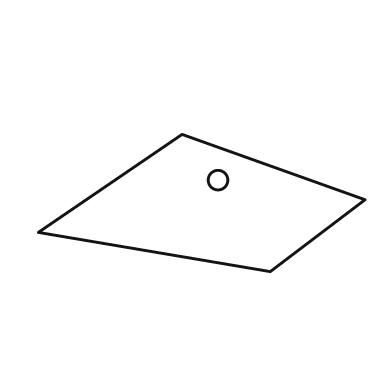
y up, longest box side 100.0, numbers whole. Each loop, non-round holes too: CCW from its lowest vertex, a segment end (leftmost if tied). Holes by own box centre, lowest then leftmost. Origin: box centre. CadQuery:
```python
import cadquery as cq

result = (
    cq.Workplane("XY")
    .moveTo(21.0, -21.0)
    .lineTo(50.0, 1.0)
    .lineTo(-6.0, 21.0)
    .lineTo(-50.0, -9.0)
    .close()
    .moveTo(5.0, 7.0)
    .circle(3.0)
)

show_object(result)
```